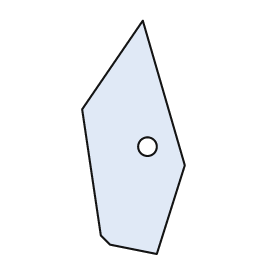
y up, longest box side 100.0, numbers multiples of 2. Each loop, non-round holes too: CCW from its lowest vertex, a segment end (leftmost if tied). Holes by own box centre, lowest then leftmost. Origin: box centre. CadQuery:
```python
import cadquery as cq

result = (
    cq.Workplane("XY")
    .moveTo(10.0, -50.0)
    .lineTo(22.0, -12.0)
    .lineTo(4.0, 50.0)
    .lineTo(-22.0, 12.0)
    .lineTo(-14.0, -42.0)
    .lineTo(-10.0, -46.0)
    .close()
    .moveTo(6.0, -4.0)
    .circle(4.0)
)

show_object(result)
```